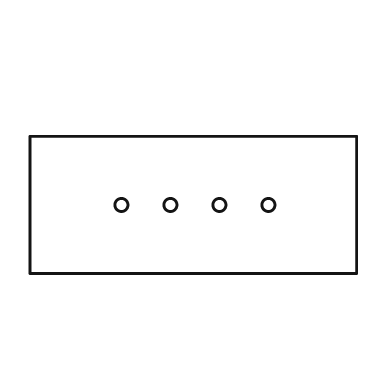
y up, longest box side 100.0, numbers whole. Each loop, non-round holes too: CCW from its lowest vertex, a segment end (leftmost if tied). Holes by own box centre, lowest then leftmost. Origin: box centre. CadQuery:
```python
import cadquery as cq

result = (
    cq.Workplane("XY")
    .moveTo(-50.0, -21.0)
    .lineTo(50.0, -21.0)
    .lineTo(50.0, 21.0)
    .lineTo(-50.0, 21.0)
    .close()
    .moveTo(-22.0, 0.0)
    .circle(2.0)
    .moveTo(-7.0, 0.0)
    .circle(2.0)
    .moveTo(8.0, 0.0)
    .circle(2.0)
    .moveTo(23.0, 0.0)
    .circle(2.0)
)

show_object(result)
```